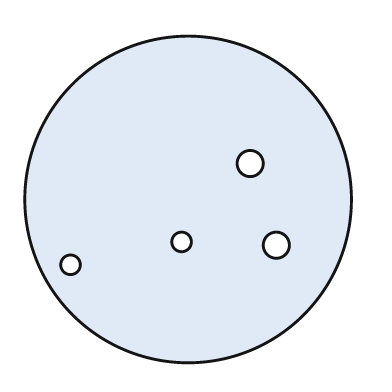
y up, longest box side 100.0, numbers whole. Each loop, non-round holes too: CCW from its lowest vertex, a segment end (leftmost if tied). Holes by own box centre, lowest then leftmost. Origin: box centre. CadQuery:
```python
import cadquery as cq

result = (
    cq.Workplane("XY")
    .moveTo(0.0, 0.0)
    .circle(50.0)
    .moveTo(-36.0, -20.0)
    .circle(3.0)
    .moveTo(27.0, -14.0)
    .circle(4.0)
    .moveTo(-2.0, -13.0)
    .circle(3.0)
    .moveTo(19.0, 11.0)
    .circle(4.0)
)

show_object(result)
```